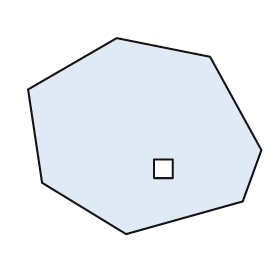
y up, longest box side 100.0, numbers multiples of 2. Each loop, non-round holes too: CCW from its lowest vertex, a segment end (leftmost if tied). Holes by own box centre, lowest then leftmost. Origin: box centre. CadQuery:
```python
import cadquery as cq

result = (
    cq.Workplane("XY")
    .moveTo(-8.0, -42.0)
    .lineTo(42.0, -28.0)
    .lineTo(50.0, -6.0)
    .lineTo(28.0, 34.0)
    .lineTo(-12.0, 42.0)
    .lineTo(-50.0, 20.0)
    .lineTo(-44.0, -20.0)
    .close()
    .moveTo(4.0, -18.0)
    .lineTo(12.0, -18.0)
    .lineTo(12.0, -10.0)
    .lineTo(4.0, -10.0)
    .close()
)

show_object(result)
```